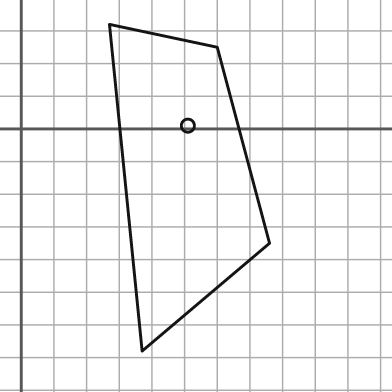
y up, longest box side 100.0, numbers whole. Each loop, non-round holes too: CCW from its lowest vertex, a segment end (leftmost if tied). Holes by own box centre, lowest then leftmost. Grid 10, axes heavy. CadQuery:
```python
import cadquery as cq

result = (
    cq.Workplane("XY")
    .moveTo(37.0, -68.0)
    .lineTo(76.0, -35.0)
    .lineTo(60.0, 25.0)
    .lineTo(27.0, 32.0)
    .close()
    .moveTo(51.0, 1.0)
    .circle(2.0)
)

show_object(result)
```